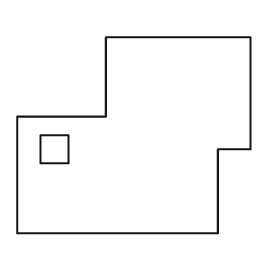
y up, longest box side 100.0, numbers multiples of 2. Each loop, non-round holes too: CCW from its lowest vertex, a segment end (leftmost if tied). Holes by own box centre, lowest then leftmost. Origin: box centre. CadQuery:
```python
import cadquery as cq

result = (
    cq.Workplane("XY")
    .moveTo(-50.0, -42.0)
    .lineTo(36.0, -42.0)
    .lineTo(36.0, -6.0)
    .lineTo(50.0, -6.0)
    .lineTo(50.0, 42.0)
    .lineTo(-12.0, 42.0)
    .lineTo(-12.0, 8.0)
    .lineTo(-50.0, 8.0)
    .close()
    .moveTo(-40.0, -12.0)
    .lineTo(-28.0, -12.0)
    .lineTo(-28.0, 0.0)
    .lineTo(-40.0, 0.0)
    .close()
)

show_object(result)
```